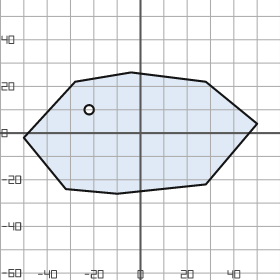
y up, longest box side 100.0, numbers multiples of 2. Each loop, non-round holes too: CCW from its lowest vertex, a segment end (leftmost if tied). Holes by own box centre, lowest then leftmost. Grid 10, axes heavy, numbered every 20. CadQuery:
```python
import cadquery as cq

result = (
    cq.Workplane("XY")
    .moveTo(-10.0, -26.0)
    .lineTo(28.0, -22.0)
    .lineTo(50.0, 4.0)
    .lineTo(28.0, 22.0)
    .lineTo(-4.0, 26.0)
    .lineTo(-28.0, 22.0)
    .lineTo(-50.0, -2.0)
    .lineTo(-32.0, -24.0)
    .close()
    .moveTo(-22.0, 10.0)
    .circle(2.0)
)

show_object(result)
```